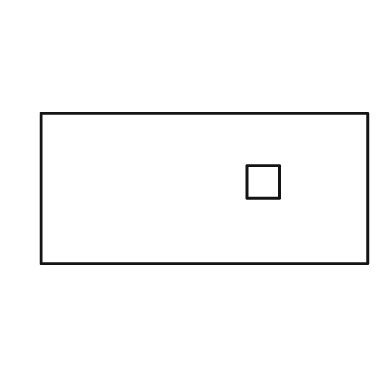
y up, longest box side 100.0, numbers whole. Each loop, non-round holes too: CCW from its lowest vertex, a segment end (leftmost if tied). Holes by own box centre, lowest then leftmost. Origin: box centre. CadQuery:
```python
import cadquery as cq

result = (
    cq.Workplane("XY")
    .moveTo(-50.0, -23.0)
    .lineTo(50.0, -23.0)
    .lineTo(50.0, 23.0)
    .lineTo(-50.0, 23.0)
    .close()
    .moveTo(13.0, -3.0)
    .lineTo(23.0, -3.0)
    .lineTo(23.0, 7.0)
    .lineTo(13.0, 7.0)
    .close()
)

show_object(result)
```